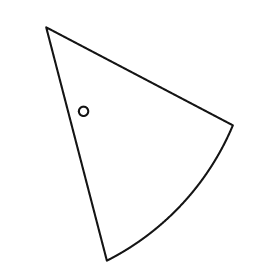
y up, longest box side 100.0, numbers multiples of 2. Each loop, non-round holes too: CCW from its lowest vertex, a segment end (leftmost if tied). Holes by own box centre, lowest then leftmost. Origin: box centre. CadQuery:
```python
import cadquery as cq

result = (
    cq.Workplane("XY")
    .moveTo(-14.0, -50.0)
    .threePointArc((18.0, -26.0), (40.0, 8.0))
    .lineTo(-40.0, 50.0)
    .close()
    .moveTo(-24.0, 14.0)
    .circle(2.0)
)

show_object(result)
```